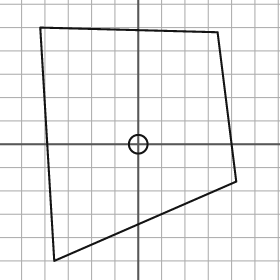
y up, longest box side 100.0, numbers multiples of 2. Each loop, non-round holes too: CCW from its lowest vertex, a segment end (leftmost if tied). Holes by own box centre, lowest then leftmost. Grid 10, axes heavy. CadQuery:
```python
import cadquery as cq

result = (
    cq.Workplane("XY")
    .moveTo(-36.0, -50.0)
    .lineTo(42.0, -16.0)
    .lineTo(34.0, 48.0)
    .lineTo(-42.0, 50.0)
    .close()
    .moveTo(0.0, 0.0)
    .circle(4.0)
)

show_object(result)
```